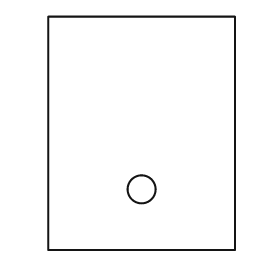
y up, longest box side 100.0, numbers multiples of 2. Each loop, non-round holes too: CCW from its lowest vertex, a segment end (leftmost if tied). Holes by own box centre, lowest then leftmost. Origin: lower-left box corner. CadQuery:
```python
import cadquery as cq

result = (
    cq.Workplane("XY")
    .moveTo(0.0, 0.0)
    .lineTo(80.0, 0.0)
    .lineTo(80.0, 100.0)
    .lineTo(0.0, 100.0)
    .close()
    .moveTo(40.0, 26.0)
    .circle(6.0)
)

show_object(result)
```